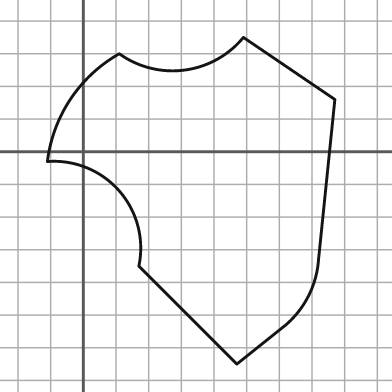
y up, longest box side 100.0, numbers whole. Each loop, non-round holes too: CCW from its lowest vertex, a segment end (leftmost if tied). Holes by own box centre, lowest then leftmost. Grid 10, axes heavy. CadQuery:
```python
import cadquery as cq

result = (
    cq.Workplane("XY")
    .moveTo(47.0, -65.0)
    .lineTo(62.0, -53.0)
    .threePointArc((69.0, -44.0), (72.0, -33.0))
    .lineTo(77.0, 16.0)
    .lineTo(49.0, 35.0)
    .threePointArc((31.0, 25.0), (11.0, 30.0))
    .threePointArc((-4.0, 16.0), (-11.0, -3.0))
    .threePointArc((11.0, -12.0), (17.0, -35.0))
    .close()
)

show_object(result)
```